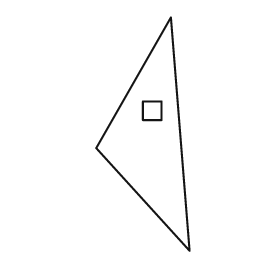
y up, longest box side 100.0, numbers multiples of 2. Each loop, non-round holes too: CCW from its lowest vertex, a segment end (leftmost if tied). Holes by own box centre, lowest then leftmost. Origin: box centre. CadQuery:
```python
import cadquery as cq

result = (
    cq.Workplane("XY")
    .moveTo(20.0, -50.0)
    .lineTo(12.0, 50.0)
    .lineTo(-20.0, -6.0)
    .close()
    .moveTo(0.0, 6.0)
    .lineTo(8.0, 6.0)
    .lineTo(8.0, 14.0)
    .lineTo(0.0, 14.0)
    .close()
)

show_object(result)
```